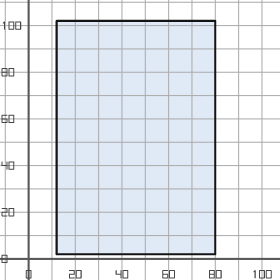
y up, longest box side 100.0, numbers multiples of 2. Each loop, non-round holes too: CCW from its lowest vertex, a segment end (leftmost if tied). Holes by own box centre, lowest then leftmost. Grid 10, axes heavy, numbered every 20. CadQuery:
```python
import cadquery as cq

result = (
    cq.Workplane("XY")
    .moveTo(12.0, 2.0)
    .lineTo(80.0, 2.0)
    .lineTo(80.0, 102.0)
    .lineTo(12.0, 102.0)
    .close()
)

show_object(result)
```